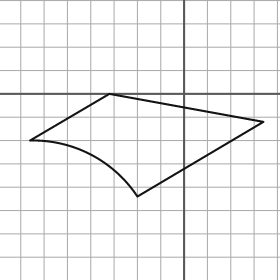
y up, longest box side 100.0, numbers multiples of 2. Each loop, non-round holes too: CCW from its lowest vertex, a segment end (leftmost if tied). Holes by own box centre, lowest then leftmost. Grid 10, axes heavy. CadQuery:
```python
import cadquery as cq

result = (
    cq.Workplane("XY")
    .moveTo(-20.0, -44.0)
    .lineTo(34.0, -12.0)
    .lineTo(-32.0, 0.0)
    .lineTo(-66.0, -20.0)
    .threePointArc((-40.0, -26.0), (-20.0, -44.0))
    .close()
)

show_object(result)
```